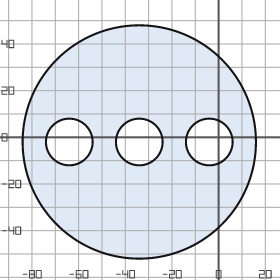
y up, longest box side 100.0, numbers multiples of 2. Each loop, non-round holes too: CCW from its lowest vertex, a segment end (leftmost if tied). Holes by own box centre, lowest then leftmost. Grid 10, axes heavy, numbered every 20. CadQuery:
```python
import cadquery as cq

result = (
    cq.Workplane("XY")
    .moveTo(-34.0, -2.0)
    .circle(50.0)
    .moveTo(-64.0, -2.0)
    .circle(10.0)
    .moveTo(-34.0, -2.0)
    .circle(10.0)
    .moveTo(-4.0, -2.0)
    .circle(10.0)
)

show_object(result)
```